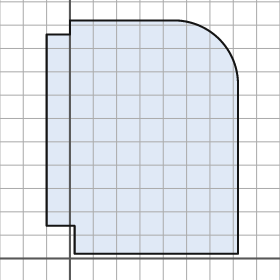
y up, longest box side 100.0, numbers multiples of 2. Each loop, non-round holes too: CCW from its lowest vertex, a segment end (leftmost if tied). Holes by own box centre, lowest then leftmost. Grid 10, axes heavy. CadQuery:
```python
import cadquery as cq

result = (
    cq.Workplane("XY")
    .moveTo(2.0, 2.0)
    .lineTo(72.0, 2.0)
    .lineTo(72.0, 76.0)
    .threePointArc((64.0, 94.0), (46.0, 102.0))
    .lineTo(0.0, 102.0)
    .lineTo(0.0, 96.0)
    .lineTo(-10.0, 96.0)
    .lineTo(-10.0, 14.0)
    .lineTo(2.0, 14.0)
    .close()
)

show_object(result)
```